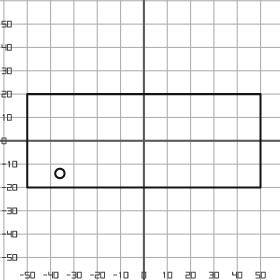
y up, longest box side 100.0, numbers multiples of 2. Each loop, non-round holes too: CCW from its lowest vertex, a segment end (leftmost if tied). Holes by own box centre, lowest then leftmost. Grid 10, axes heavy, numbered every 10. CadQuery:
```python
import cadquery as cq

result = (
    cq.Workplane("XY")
    .moveTo(-50.0, -20.0)
    .lineTo(50.0, -20.0)
    .lineTo(50.0, 20.0)
    .lineTo(-50.0, 20.0)
    .close()
    .moveTo(-36.0, -14.0)
    .circle(2.0)
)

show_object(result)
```